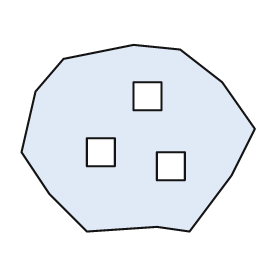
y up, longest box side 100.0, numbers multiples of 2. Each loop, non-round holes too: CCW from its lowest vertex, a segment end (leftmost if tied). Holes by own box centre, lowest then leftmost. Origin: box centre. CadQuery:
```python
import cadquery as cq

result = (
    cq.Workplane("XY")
    .moveTo(-22.0, -40.0)
    .lineTo(8.0, -38.0)
    .lineTo(22.0, -40.0)
    .lineTo(40.0, -16.0)
    .lineTo(50.0, 4.0)
    .lineTo(36.0, 24.0)
    .lineTo(18.0, 38.0)
    .lineTo(-2.0, 40.0)
    .lineTo(-32.0, 34.0)
    .lineTo(-44.0, 20.0)
    .lineTo(-50.0, -6.0)
    .lineTo(-38.0, -24.0)
    .close()
    .moveTo(8.0, -18.0)
    .lineTo(20.0, -18.0)
    .lineTo(20.0, -6.0)
    .lineTo(8.0, -6.0)
    .close()
    .moveTo(-22.0, -12.0)
    .lineTo(-10.0, -12.0)
    .lineTo(-10.0, 0.0)
    .lineTo(-22.0, 0.0)
    .close()
    .moveTo(-2.0, 12.0)
    .lineTo(10.0, 12.0)
    .lineTo(10.0, 24.0)
    .lineTo(-2.0, 24.0)
    .close()
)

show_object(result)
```